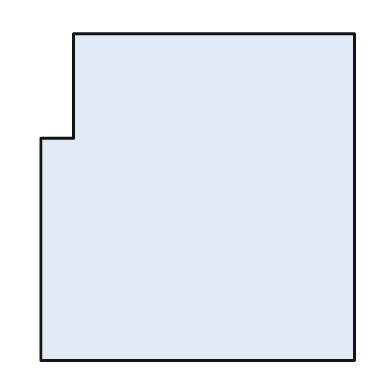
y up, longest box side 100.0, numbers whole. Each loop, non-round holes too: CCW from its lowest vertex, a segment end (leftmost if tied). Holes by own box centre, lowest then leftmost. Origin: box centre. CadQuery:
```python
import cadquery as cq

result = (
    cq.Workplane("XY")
    .moveTo(-48.0, -50.0)
    .lineTo(48.0, -50.0)
    .lineTo(48.0, 50.0)
    .lineTo(-38.0, 50.0)
    .lineTo(-38.0, 18.0)
    .lineTo(-48.0, 18.0)
    .close()
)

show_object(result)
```